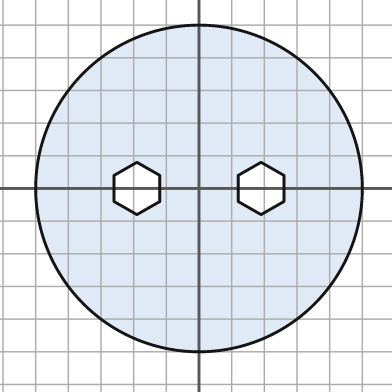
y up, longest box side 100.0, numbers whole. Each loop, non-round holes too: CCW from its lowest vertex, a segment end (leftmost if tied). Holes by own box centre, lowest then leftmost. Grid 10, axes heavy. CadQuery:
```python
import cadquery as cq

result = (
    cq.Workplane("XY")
    .moveTo(0.0, 0.0)
    .circle(50.0)
    .moveTo(-19.0, -8.0)
    .lineTo(-12.0, -4.0)
    .lineTo(-12.0, 4.0)
    .lineTo(-19.0, 8.0)
    .lineTo(-26.0, 4.0)
    .lineTo(-26.0, -4.0)
    .close()
    .moveTo(19.0, -8.0)
    .lineTo(26.0, -4.0)
    .lineTo(26.0, 4.0)
    .lineTo(19.0, 8.0)
    .lineTo(12.0, 4.0)
    .lineTo(12.0, -4.0)
    .close()
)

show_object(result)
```